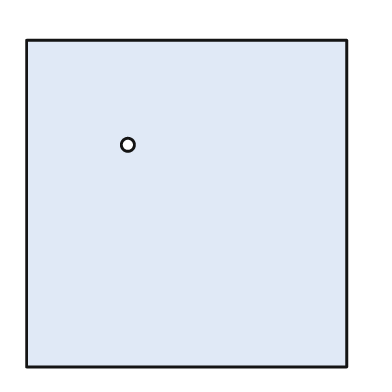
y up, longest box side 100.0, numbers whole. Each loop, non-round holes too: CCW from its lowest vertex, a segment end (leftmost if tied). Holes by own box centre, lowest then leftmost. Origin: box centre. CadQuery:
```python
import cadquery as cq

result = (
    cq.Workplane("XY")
    .moveTo(-49.0, -50.0)
    .lineTo(49.0, -50.0)
    .lineTo(49.0, 50.0)
    .lineTo(-49.0, 50.0)
    .close()
    .moveTo(-18.0, 18.0)
    .circle(2.0)
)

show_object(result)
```